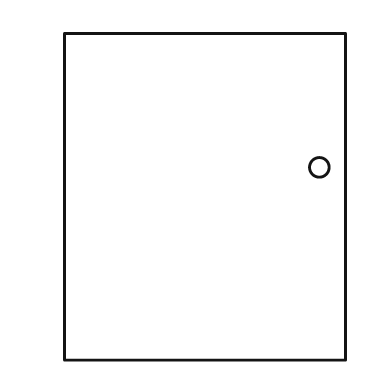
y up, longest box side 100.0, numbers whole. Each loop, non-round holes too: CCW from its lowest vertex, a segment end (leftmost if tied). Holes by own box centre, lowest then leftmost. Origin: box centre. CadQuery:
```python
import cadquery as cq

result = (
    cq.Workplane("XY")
    .moveTo(-43.0, -50.0)
    .lineTo(43.0, -50.0)
    .lineTo(43.0, 50.0)
    .lineTo(-43.0, 50.0)
    .close()
    .moveTo(35.0, 9.0)
    .circle(3.0)
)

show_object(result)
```